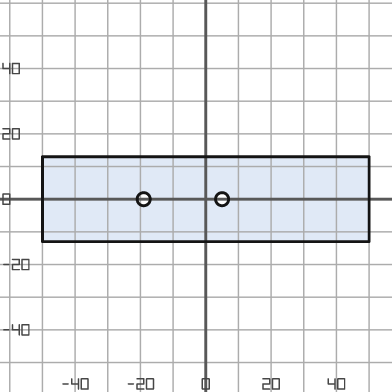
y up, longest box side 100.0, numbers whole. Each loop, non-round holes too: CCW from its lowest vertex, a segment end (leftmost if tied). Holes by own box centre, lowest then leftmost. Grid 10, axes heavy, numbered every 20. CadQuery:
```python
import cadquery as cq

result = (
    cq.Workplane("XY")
    .moveTo(-50.0, -13.0)
    .lineTo(50.0, -13.0)
    .lineTo(50.0, 13.0)
    .lineTo(-50.0, 13.0)
    .close()
    .moveTo(-19.0, 0.0)
    .circle(2.0)
    .moveTo(5.0, 0.0)
    .circle(2.0)
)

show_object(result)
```